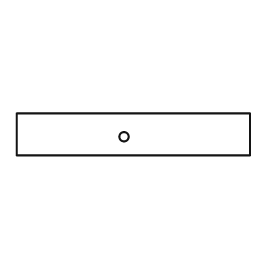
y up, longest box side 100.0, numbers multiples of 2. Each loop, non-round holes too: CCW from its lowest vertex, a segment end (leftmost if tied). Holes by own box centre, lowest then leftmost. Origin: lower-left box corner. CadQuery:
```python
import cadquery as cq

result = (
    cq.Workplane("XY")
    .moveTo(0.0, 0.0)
    .lineTo(100.0, 0.0)
    .lineTo(100.0, 18.0)
    .lineTo(0.0, 18.0)
    .close()
    .moveTo(46.0, 8.0)
    .circle(2.0)
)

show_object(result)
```